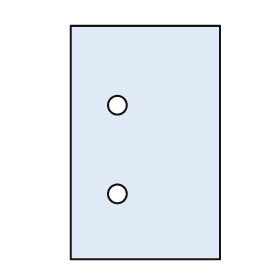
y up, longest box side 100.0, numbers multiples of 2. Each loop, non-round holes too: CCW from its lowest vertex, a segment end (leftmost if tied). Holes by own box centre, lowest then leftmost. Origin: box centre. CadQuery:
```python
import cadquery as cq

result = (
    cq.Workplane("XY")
    .moveTo(-32.0, -50.0)
    .lineTo(32.0, -50.0)
    .lineTo(32.0, 50.0)
    .lineTo(-32.0, 50.0)
    .close()
    .moveTo(-12.0, -22.0)
    .circle(4.0)
    .moveTo(-12.0, 16.0)
    .circle(4.0)
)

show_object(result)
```